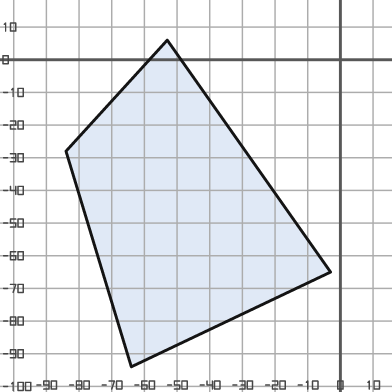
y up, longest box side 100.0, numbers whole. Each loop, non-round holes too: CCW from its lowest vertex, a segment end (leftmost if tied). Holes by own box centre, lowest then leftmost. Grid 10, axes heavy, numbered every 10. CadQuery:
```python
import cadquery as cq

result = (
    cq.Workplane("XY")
    .moveTo(-64.0, -94.0)
    .lineTo(-3.0, -65.0)
    .lineTo(-53.0, 6.0)
    .lineTo(-84.0, -28.0)
    .close()
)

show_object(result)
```